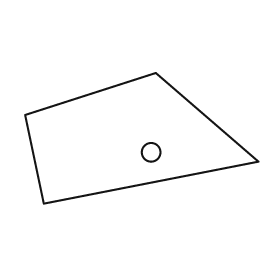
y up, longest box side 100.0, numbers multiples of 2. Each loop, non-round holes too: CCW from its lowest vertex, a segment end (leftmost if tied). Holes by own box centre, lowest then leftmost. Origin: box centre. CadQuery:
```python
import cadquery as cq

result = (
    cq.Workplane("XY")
    .moveTo(-42.0, -28.0)
    .lineTo(50.0, -10.0)
    .lineTo(6.0, 28.0)
    .lineTo(-50.0, 10.0)
    .close()
    .moveTo(4.0, -6.0)
    .circle(4.0)
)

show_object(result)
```